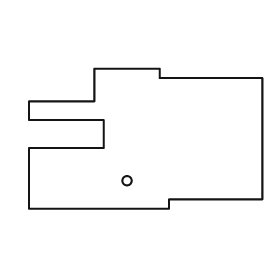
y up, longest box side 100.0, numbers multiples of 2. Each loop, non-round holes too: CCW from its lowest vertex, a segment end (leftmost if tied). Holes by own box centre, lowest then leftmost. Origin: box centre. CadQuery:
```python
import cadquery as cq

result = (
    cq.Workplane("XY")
    .moveTo(-50.0, -30.0)
    .lineTo(10.0, -30.0)
    .lineTo(10.0, -26.0)
    .lineTo(50.0, -26.0)
    .lineTo(50.0, 26.0)
    .lineTo(6.0, 26.0)
    .lineTo(6.0, 30.0)
    .lineTo(-22.0, 30.0)
    .lineTo(-22.0, 16.0)
    .lineTo(-50.0, 16.0)
    .lineTo(-50.0, 8.0)
    .lineTo(-18.0, 8.0)
    .lineTo(-18.0, -4.0)
    .lineTo(-50.0, -4.0)
    .close()
    .moveTo(-8.0, -18.0)
    .circle(2.0)
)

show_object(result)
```